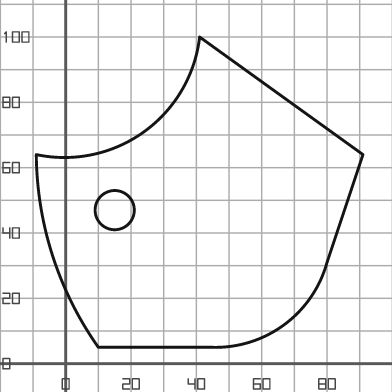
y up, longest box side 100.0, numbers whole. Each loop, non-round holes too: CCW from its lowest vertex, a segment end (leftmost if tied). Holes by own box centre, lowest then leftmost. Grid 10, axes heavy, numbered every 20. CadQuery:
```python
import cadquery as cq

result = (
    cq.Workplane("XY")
    .moveTo(10.0, 5.0)
    .lineTo(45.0, 5.0)
    .threePointArc((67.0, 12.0), (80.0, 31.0))
    .lineTo(91.0, 64.0)
    .lineTo(41.0, 100.0)
    .threePointArc((24.0, 71.0), (-9.0, 64.0))
    .threePointArc((-4.0, 33.0), (10.0, 5.0))
    .close()
    .moveTo(15.0, 47.0)
    .circle(6.0)
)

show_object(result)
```